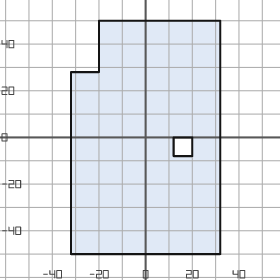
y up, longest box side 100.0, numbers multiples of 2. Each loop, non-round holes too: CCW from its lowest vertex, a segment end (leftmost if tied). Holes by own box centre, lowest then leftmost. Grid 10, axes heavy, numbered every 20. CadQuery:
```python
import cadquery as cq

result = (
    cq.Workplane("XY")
    .moveTo(-32.0, -50.0)
    .lineTo(32.0, -50.0)
    .lineTo(32.0, 50.0)
    .lineTo(-20.0, 50.0)
    .lineTo(-20.0, 28.0)
    .lineTo(-32.0, 28.0)
    .close()
    .moveTo(12.0, -8.0)
    .lineTo(20.0, -8.0)
    .lineTo(20.0, 0.0)
    .lineTo(12.0, 0.0)
    .close()
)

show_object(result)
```